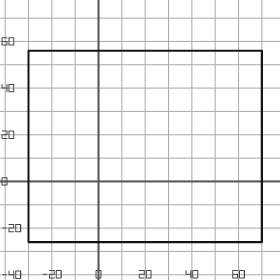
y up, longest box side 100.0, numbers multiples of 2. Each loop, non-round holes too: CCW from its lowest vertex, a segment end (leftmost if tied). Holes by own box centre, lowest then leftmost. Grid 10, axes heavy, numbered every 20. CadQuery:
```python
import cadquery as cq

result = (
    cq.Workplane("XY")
    .moveTo(-30.0, -26.0)
    .lineTo(70.0, -26.0)
    .lineTo(70.0, 56.0)
    .lineTo(-30.0, 56.0)
    .close()
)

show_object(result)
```